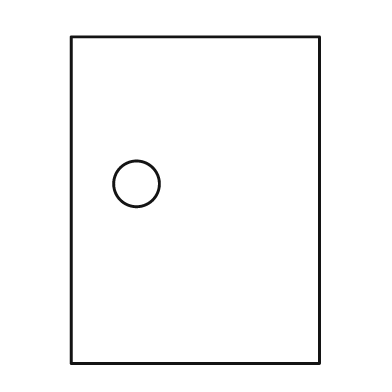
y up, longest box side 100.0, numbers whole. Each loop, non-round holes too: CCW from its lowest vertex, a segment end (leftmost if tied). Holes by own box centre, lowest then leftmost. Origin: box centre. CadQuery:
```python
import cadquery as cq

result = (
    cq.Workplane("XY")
    .moveTo(-38.0, -50.0)
    .lineTo(38.0, -50.0)
    .lineTo(38.0, 50.0)
    .lineTo(-38.0, 50.0)
    .close()
    .moveTo(-18.0, 5.0)
    .circle(7.0)
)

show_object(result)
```